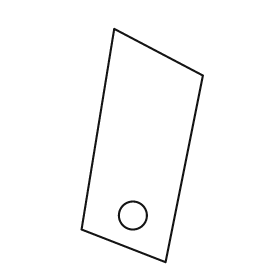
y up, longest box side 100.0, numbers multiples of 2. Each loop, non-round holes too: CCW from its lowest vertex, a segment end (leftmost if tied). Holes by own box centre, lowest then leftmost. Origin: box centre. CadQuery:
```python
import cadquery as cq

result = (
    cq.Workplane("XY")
    .moveTo(10.0, -50.0)
    .lineTo(26.0, 30.0)
    .lineTo(-12.0, 50.0)
    .lineTo(-26.0, -36.0)
    .close()
    .moveTo(-4.0, -30.0)
    .circle(6.0)
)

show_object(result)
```